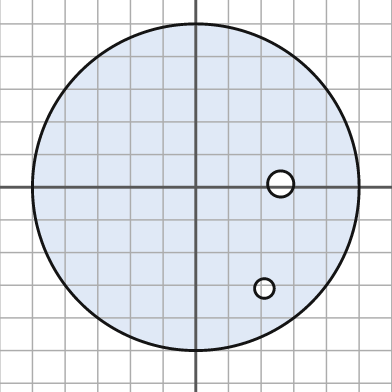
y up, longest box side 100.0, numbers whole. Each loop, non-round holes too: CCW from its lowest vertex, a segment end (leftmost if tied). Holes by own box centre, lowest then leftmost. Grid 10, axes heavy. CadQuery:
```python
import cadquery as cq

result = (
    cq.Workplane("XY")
    .moveTo(0.0, 0.0)
    .circle(50.0)
    .moveTo(21.0, -31.0)
    .circle(3.0)
    .moveTo(26.0, 1.0)
    .circle(4.0)
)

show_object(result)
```